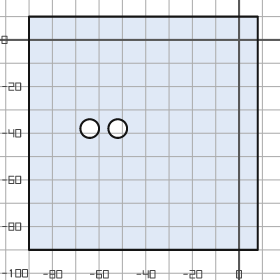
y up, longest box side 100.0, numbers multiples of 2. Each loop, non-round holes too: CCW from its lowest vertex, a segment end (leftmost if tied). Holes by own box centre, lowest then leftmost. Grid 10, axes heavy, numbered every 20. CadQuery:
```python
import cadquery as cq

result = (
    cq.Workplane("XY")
    .moveTo(-90.0, -90.0)
    .lineTo(8.0, -90.0)
    .lineTo(8.0, 10.0)
    .lineTo(-90.0, 10.0)
    .close()
    .moveTo(-64.0, -38.0)
    .circle(4.0)
    .moveTo(-52.0, -38.0)
    .circle(4.0)
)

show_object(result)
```